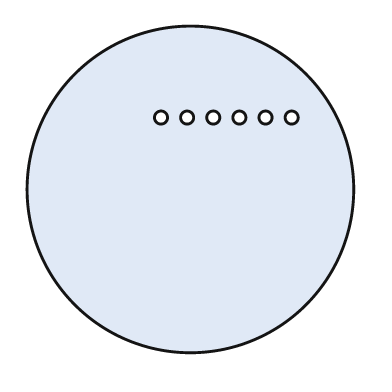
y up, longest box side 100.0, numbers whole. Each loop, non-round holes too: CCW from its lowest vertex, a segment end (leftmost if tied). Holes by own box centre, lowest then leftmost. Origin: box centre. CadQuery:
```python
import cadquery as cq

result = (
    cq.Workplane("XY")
    .moveTo(0.0, 0.0)
    .circle(50.0)
    .moveTo(-9.0, 22.0)
    .circle(2.0)
    .moveTo(-1.0, 22.0)
    .circle(2.0)
    .moveTo(7.0, 22.0)
    .circle(2.0)
    .moveTo(15.0, 22.0)
    .circle(2.0)
    .moveTo(23.0, 22.0)
    .circle(2.0)
    .moveTo(31.0, 22.0)
    .circle(2.0)
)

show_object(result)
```